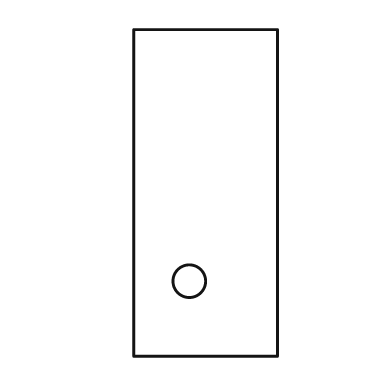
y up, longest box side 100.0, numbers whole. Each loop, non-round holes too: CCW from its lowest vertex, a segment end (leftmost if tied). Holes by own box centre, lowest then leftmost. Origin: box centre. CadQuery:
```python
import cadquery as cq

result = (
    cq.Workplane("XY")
    .moveTo(-22.0, -50.0)
    .lineTo(22.0, -50.0)
    .lineTo(22.0, 50.0)
    .lineTo(-22.0, 50.0)
    .close()
    .moveTo(-5.0, -27.0)
    .circle(5.0)
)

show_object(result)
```